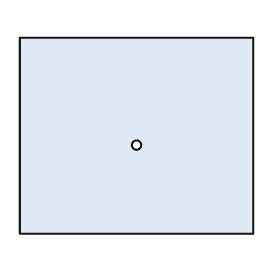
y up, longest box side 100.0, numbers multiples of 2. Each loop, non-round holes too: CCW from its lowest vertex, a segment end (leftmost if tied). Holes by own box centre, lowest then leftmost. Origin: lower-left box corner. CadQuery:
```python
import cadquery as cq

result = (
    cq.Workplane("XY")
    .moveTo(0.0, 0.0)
    .lineTo(100.0, 0.0)
    .lineTo(100.0, 84.0)
    .lineTo(0.0, 84.0)
    .close()
    .moveTo(50.0, 38.0)
    .circle(2.0)
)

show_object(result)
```